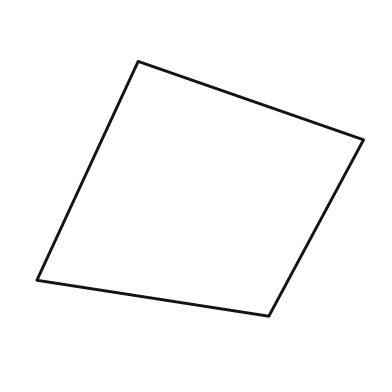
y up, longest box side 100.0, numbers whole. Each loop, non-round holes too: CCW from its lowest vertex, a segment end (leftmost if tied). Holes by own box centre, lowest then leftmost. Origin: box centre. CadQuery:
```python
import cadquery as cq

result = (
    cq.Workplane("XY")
    .moveTo(21.0, -39.0)
    .lineTo(50.0, 15.0)
    .lineTo(-19.0, 39.0)
    .lineTo(-50.0, -28.0)
    .close()
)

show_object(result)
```